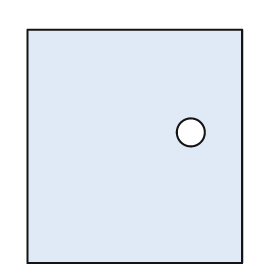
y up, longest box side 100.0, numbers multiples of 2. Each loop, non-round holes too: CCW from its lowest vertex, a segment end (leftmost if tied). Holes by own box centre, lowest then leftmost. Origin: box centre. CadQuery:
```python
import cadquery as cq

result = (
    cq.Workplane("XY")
    .moveTo(-46.0, -50.0)
    .lineTo(46.0, -50.0)
    .lineTo(46.0, 50.0)
    .lineTo(-46.0, 50.0)
    .close()
    .moveTo(24.0, 6.0)
    .circle(6.0)
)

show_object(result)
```